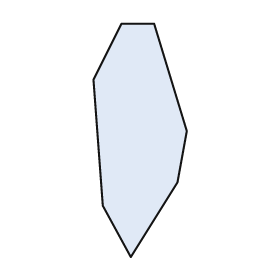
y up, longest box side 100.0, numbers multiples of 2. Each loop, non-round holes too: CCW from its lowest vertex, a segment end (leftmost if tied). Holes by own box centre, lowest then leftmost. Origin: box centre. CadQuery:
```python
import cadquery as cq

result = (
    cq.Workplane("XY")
    .moveTo(-4.0, -50.0)
    .lineTo(16.0, -18.0)
    .lineTo(20.0, 4.0)
    .lineTo(6.0, 50.0)
    .lineTo(-8.0, 50.0)
    .lineTo(-20.0, 26.0)
    .lineTo(-16.0, -28.0)
    .close()
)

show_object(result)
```